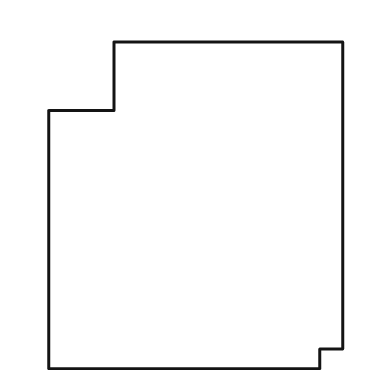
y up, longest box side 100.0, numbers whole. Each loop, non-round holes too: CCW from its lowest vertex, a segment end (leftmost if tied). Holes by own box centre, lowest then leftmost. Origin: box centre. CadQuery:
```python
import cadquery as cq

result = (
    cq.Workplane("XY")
    .moveTo(-45.0, -50.0)
    .lineTo(38.0, -50.0)
    .lineTo(38.0, -44.0)
    .lineTo(45.0, -44.0)
    .lineTo(45.0, 50.0)
    .lineTo(-25.0, 50.0)
    .lineTo(-25.0, 29.0)
    .lineTo(-45.0, 29.0)
    .close()
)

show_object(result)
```